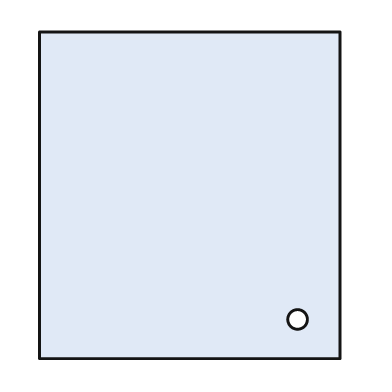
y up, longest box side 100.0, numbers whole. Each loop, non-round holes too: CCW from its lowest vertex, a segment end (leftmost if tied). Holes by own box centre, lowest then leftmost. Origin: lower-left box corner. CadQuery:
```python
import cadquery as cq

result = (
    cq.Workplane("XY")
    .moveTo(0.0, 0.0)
    .lineTo(92.0, 0.0)
    .lineTo(92.0, 100.0)
    .lineTo(0.0, 100.0)
    .close()
    .moveTo(79.0, 12.0)
    .circle(3.0)
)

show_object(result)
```